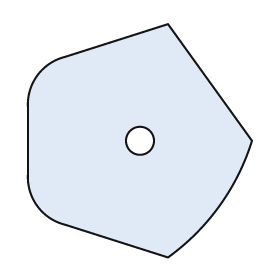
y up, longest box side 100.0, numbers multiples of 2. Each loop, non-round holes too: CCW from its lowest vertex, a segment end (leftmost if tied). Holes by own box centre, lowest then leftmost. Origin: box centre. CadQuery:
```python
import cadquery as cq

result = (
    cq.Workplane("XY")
    .moveTo(12.0, -50.0)
    .threePointArc((34.0, -28.0), (48.0, 0.0))
    .lineTo(12.0, 50.0)
    .lineTo(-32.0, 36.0)
    .threePointArc((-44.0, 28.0), (-48.0, 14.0))
    .lineTo(-48.0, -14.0)
    .threePointArc((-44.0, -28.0), (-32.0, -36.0))
    .close()
    .moveTo(0.0, 0.0)
    .circle(6.0)
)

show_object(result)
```